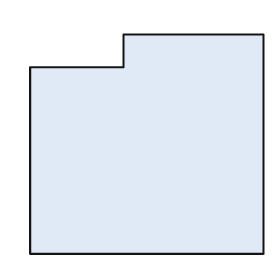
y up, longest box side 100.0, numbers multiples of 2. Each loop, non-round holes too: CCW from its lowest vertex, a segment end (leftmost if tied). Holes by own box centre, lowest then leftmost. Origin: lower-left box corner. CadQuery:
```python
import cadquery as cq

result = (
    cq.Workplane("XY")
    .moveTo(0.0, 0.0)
    .lineTo(100.0, 0.0)
    .lineTo(100.0, 94.0)
    .lineTo(40.0, 94.0)
    .lineTo(40.0, 80.0)
    .lineTo(0.0, 80.0)
    .close()
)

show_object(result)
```